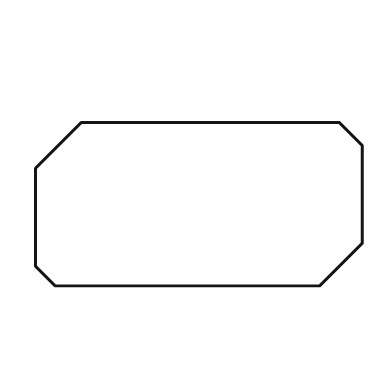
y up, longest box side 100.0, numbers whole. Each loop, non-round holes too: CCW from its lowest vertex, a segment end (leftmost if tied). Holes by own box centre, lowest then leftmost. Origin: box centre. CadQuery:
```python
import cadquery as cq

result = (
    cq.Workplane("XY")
    .moveTo(-44.0, -25.0)
    .lineTo(37.0, -25.0)
    .lineTo(50.0, -12.0)
    .lineTo(50.0, 18.0)
    .lineTo(43.0, 25.0)
    .lineTo(-36.0, 25.0)
    .lineTo(-50.0, 11.0)
    .lineTo(-50.0, -19.0)
    .close()
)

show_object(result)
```